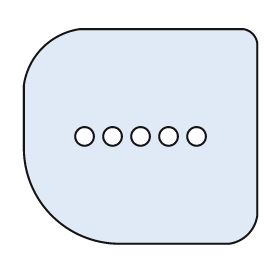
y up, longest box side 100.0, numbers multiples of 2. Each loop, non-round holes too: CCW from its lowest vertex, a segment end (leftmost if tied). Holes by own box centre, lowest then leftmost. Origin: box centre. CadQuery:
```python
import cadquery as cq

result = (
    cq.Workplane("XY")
    .moveTo(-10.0, -46.0)
    .lineTo(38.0, -46.0)
    .threePointArc((46.0, -42.0), (50.0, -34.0))
    .lineTo(50.0, 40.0)
    .threePointArc((48.0, 44.0), (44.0, 46.0))
    .lineTo(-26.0, 46.0)
    .threePointArc((-42.0, 38.0), (-50.0, 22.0))
    .lineTo(-50.0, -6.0)
    .threePointArc((-38.0, -34.0), (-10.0, -46.0))
    .close()
    .moveTo(-24.0, 0.0)
    .circle(4.0)
    .moveTo(-12.0, 0.0)
    .circle(4.0)
    .moveTo(0.0, 0.0)
    .circle(4.0)
    .moveTo(12.0, 0.0)
    .circle(4.0)
    .moveTo(24.0, 0.0)
    .circle(4.0)
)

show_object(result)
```